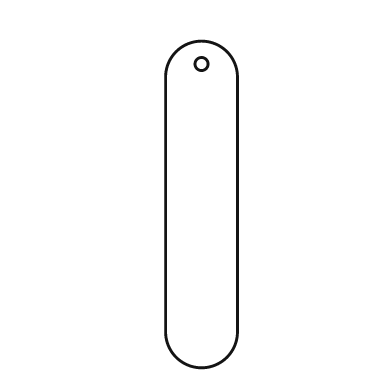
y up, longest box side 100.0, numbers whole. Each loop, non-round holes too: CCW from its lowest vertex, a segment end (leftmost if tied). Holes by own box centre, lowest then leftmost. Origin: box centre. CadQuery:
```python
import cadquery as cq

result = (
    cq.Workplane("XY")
    .moveTo(-11.0, -39.0)
    .threePointArc((0.0, -50.0), (11.0, -39.0))
    .lineTo(11.0, 39.0)
    .threePointArc((0.0, 50.0), (-11.0, 39.0))
    .close()
    .moveTo(0.0, 43.0)
    .circle(2.0)
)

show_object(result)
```